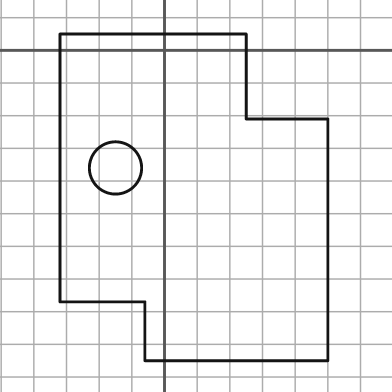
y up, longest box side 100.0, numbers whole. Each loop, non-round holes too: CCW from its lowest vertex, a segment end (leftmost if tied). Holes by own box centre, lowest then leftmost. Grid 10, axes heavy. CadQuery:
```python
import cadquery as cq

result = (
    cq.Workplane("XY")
    .moveTo(-6.0, -95.0)
    .lineTo(50.0, -95.0)
    .lineTo(50.0, -21.0)
    .lineTo(25.0, -21.0)
    .lineTo(25.0, 5.0)
    .lineTo(-32.0, 5.0)
    .lineTo(-32.0, -77.0)
    .lineTo(-6.0, -77.0)
    .close()
    .moveTo(-15.0, -36.0)
    .circle(8.0)
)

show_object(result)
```